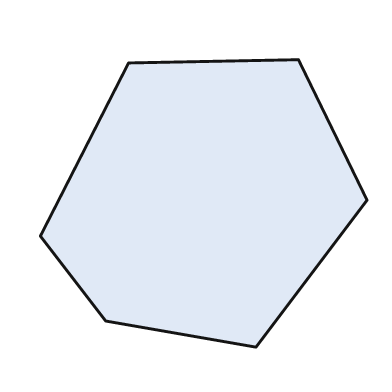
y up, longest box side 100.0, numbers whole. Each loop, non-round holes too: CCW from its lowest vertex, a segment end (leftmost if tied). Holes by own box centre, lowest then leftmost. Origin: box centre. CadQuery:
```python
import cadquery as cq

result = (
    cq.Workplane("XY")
    .moveTo(16.0, -44.0)
    .lineTo(50.0, 1.0)
    .lineTo(29.0, 44.0)
    .lineTo(-23.0, 43.0)
    .lineTo(-50.0, -10.0)
    .lineTo(-30.0, -36.0)
    .close()
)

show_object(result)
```